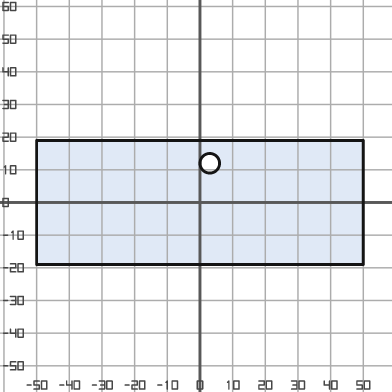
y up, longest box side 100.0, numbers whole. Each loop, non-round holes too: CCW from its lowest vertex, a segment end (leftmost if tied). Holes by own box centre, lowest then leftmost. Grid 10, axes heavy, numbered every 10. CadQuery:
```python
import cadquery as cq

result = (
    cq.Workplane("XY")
    .moveTo(-50.0, -19.0)
    .lineTo(50.0, -19.0)
    .lineTo(50.0, 19.0)
    .lineTo(-50.0, 19.0)
    .close()
    .moveTo(3.0, 12.0)
    .circle(3.0)
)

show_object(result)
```